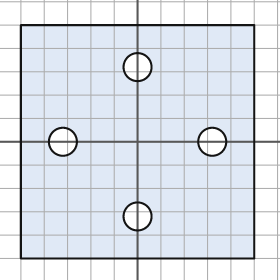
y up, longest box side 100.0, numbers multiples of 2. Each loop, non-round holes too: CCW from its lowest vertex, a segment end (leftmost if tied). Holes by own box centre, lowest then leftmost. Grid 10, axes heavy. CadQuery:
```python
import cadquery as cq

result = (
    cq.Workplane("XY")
    .moveTo(-50.0, -50.0)
    .lineTo(50.0, -50.0)
    .lineTo(50.0, 50.0)
    .lineTo(-50.0, 50.0)
    .close()
    .moveTo(0.0, -32.0)
    .circle(6.0)
    .moveTo(-32.0, 0.0)
    .circle(6.0)
    .moveTo(32.0, 0.0)
    .circle(6.0)
    .moveTo(0.0, 32.0)
    .circle(6.0)
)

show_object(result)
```